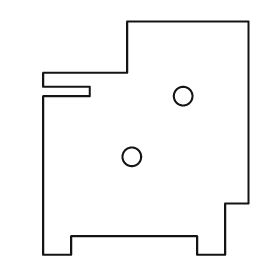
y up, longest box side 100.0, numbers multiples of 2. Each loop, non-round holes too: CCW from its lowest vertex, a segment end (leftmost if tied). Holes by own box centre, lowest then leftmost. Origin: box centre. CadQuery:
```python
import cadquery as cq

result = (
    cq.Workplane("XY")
    .moveTo(-44.0, -50.0)
    .lineTo(-32.0, -50.0)
    .lineTo(-32.0, -42.0)
    .lineTo(22.0, -42.0)
    .lineTo(22.0, -50.0)
    .lineTo(34.0, -50.0)
    .lineTo(34.0, -28.0)
    .lineTo(44.0, -28.0)
    .lineTo(44.0, 50.0)
    .lineTo(-8.0, 50.0)
    .lineTo(-8.0, 28.0)
    .lineTo(-44.0, 28.0)
    .lineTo(-44.0, 22.0)
    .lineTo(-24.0, 22.0)
    .lineTo(-24.0, 18.0)
    .lineTo(-44.0, 18.0)
    .close()
    .moveTo(-6.0, -8.0)
    .circle(4.0)
    .moveTo(16.0, 18.0)
    .circle(4.0)
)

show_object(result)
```